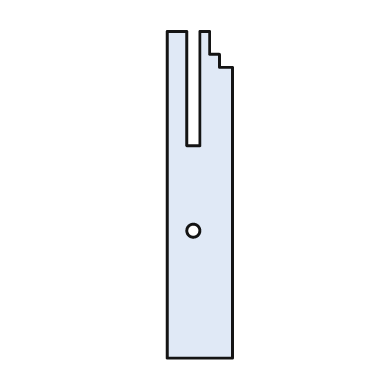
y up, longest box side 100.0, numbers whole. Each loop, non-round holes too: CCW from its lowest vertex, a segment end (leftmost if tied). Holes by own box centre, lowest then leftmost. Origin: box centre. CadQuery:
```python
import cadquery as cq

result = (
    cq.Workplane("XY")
    .moveTo(-10.0, -50.0)
    .lineTo(10.0, -50.0)
    .lineTo(10.0, 39.0)
    .lineTo(6.0, 39.0)
    .lineTo(6.0, 43.0)
    .lineTo(3.0, 43.0)
    .lineTo(3.0, 50.0)
    .lineTo(0.0, 50.0)
    .lineTo(0.0, 15.0)
    .lineTo(-4.0, 15.0)
    .lineTo(-4.0, 50.0)
    .lineTo(-10.0, 50.0)
    .close()
    .moveTo(-2.0, -11.0)
    .circle(2.0)
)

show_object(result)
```